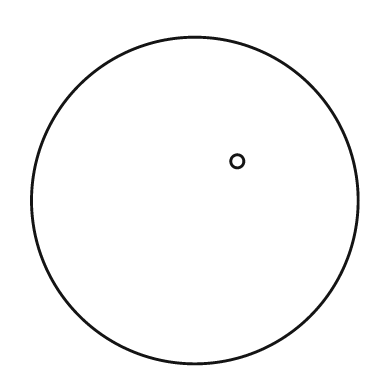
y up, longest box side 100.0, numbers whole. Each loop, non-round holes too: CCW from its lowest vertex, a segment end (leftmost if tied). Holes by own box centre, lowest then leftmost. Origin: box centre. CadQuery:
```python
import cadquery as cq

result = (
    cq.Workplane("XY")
    .moveTo(0.0, 0.0)
    .circle(50.0)
    .moveTo(13.0, 12.0)
    .circle(2.0)
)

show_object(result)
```